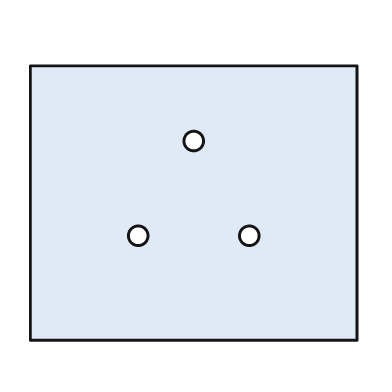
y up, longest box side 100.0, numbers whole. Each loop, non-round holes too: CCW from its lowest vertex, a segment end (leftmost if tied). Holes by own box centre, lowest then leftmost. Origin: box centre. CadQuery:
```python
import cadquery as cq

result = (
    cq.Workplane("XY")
    .moveTo(-50.0, -42.0)
    .lineTo(50.0, -42.0)
    .lineTo(50.0, 42.0)
    .lineTo(-50.0, 42.0)
    .close()
    .moveTo(-17.0, -10.0)
    .circle(3.0)
    .moveTo(17.0, -10.0)
    .circle(3.0)
    .moveTo(0.0, 19.0)
    .circle(3.0)
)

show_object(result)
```